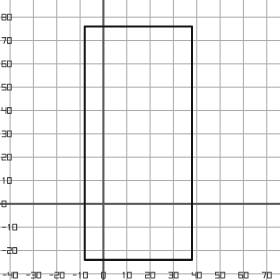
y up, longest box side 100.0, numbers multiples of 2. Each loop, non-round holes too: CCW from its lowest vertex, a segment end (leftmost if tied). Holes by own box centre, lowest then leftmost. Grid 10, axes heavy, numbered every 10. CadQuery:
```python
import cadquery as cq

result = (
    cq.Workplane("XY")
    .moveTo(-8.0, -24.0)
    .lineTo(38.0, -24.0)
    .lineTo(38.0, 76.0)
    .lineTo(-8.0, 76.0)
    .close()
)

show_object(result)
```